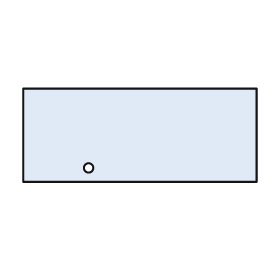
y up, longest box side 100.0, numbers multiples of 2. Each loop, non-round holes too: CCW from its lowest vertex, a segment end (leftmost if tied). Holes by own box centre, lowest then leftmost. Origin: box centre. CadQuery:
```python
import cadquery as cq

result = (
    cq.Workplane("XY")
    .moveTo(-50.0, -20.0)
    .lineTo(50.0, -20.0)
    .lineTo(50.0, 20.0)
    .lineTo(-50.0, 20.0)
    .close()
    .moveTo(-22.0, -14.0)
    .circle(2.0)
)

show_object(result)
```